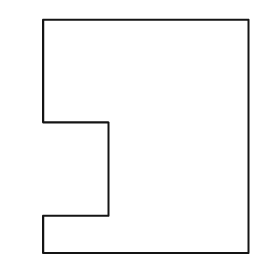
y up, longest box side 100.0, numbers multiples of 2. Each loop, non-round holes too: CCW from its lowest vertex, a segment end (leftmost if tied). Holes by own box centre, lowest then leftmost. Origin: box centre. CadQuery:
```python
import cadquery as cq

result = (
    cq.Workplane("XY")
    .moveTo(-44.0, -50.0)
    .lineTo(44.0, -50.0)
    .lineTo(44.0, 50.0)
    .lineTo(-44.0, 50.0)
    .lineTo(-44.0, 6.0)
    .lineTo(-16.0, 6.0)
    .lineTo(-16.0, -34.0)
    .lineTo(-44.0, -34.0)
    .close()
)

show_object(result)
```